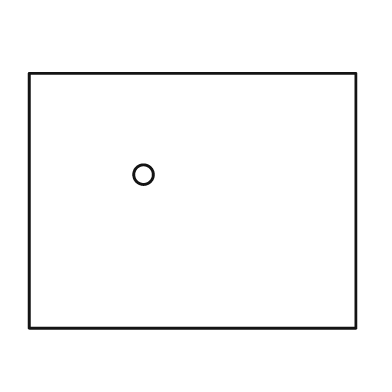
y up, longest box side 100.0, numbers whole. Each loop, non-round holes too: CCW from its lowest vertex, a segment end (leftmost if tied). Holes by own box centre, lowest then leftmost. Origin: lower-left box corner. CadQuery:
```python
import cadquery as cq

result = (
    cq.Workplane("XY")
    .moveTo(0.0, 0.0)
    .lineTo(100.0, 0.0)
    .lineTo(100.0, 78.0)
    .lineTo(0.0, 78.0)
    .close()
    .moveTo(35.0, 47.0)
    .circle(3.0)
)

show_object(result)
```